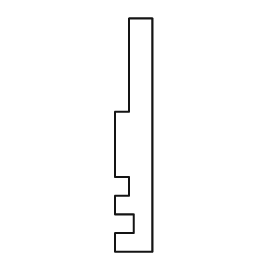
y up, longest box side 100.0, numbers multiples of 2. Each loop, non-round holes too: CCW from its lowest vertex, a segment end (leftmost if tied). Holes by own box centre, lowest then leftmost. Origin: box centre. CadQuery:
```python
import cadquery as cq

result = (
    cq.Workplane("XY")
    .moveTo(-8.0, -50.0)
    .lineTo(8.0, -50.0)
    .lineTo(8.0, 50.0)
    .lineTo(-2.0, 50.0)
    .lineTo(-2.0, 10.0)
    .lineTo(-8.0, 10.0)
    .lineTo(-8.0, -18.0)
    .lineTo(-2.0, -18.0)
    .lineTo(-2.0, -26.0)
    .lineTo(-8.0, -26.0)
    .lineTo(-8.0, -34.0)
    .lineTo(0.0, -34.0)
    .lineTo(0.0, -42.0)
    .lineTo(-8.0, -42.0)
    .close()
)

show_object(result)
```